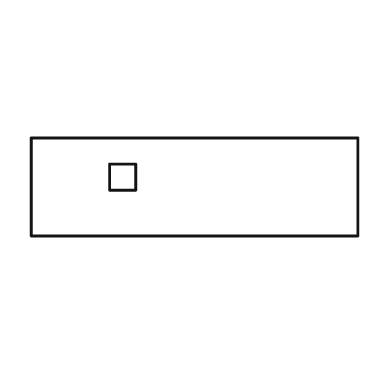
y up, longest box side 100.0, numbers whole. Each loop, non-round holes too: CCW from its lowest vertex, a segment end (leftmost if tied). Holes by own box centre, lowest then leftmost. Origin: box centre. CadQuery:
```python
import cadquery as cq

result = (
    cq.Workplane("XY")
    .moveTo(-50.0, -15.0)
    .lineTo(50.0, -15.0)
    .lineTo(50.0, 15.0)
    .lineTo(-50.0, 15.0)
    .close()
    .moveTo(-26.0, -1.0)
    .lineTo(-18.0, -1.0)
    .lineTo(-18.0, 7.0)
    .lineTo(-26.0, 7.0)
    .close()
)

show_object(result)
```